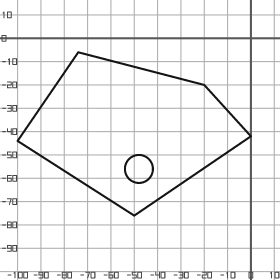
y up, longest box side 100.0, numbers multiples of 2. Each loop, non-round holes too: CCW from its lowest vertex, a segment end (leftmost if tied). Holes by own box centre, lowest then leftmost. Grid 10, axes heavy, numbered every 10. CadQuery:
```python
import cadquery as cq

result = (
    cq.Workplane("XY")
    .moveTo(-50.0, -76.0)
    .lineTo(0.0, -42.0)
    .lineTo(-20.0, -20.0)
    .lineTo(-74.0, -6.0)
    .lineTo(-100.0, -44.0)
    .close()
    .moveTo(-48.0, -56.0)
    .circle(6.0)
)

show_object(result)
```